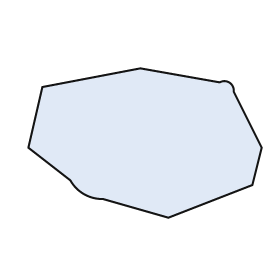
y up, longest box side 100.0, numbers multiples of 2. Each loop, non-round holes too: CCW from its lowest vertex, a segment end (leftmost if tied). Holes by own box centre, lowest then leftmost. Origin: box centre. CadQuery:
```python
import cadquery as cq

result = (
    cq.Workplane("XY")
    .moveTo(10.0, -32.0)
    .lineTo(46.0, -18.0)
    .lineTo(50.0, -2.0)
    .lineTo(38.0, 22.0)
    .threePointArc((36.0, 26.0), (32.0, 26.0))
    .lineTo(-2.0, 32.0)
    .lineTo(-44.0, 24.0)
    .lineTo(-50.0, -2.0)
    .lineTo(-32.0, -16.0)
    .threePointArc((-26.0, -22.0), (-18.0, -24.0))
    .close()
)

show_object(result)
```